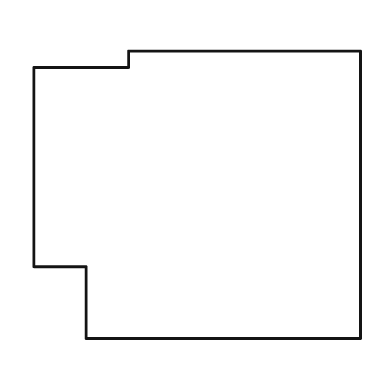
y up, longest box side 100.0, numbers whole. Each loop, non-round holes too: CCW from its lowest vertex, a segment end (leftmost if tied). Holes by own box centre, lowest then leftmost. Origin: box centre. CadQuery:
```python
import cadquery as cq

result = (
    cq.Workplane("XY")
    .moveTo(-34.0, -44.0)
    .lineTo(50.0, -44.0)
    .lineTo(50.0, 44.0)
    .lineTo(-21.0, 44.0)
    .lineTo(-21.0, 39.0)
    .lineTo(-50.0, 39.0)
    .lineTo(-50.0, -22.0)
    .lineTo(-34.0, -22.0)
    .close()
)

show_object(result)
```